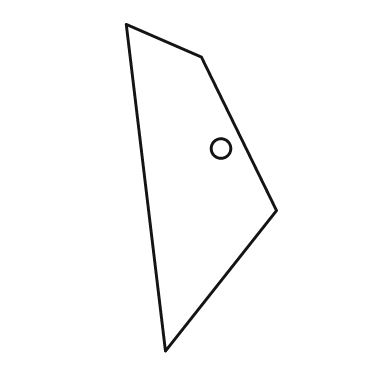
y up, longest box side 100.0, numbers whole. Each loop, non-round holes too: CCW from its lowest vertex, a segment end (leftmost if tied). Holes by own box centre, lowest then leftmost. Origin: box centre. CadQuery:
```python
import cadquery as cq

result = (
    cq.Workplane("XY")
    .moveTo(-11.0, -50.0)
    .lineTo(23.0, -7.0)
    .lineTo(0.0, 40.0)
    .lineTo(-23.0, 50.0)
    .close()
    .moveTo(6.0, 12.0)
    .circle(3.0)
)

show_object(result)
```